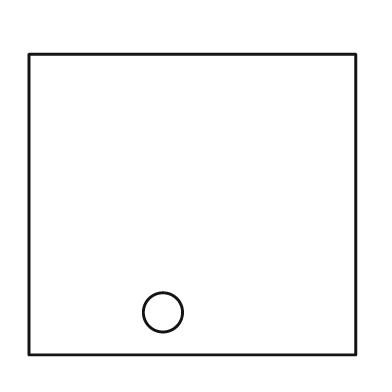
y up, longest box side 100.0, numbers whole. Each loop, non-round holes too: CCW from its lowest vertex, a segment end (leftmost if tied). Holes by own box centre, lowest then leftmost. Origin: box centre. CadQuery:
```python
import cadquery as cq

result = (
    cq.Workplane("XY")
    .moveTo(-50.0, -46.0)
    .lineTo(50.0, -46.0)
    .lineTo(50.0, 46.0)
    .lineTo(-50.0, 46.0)
    .close()
    .moveTo(-9.0, -33.0)
    .circle(6.0)
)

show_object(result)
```